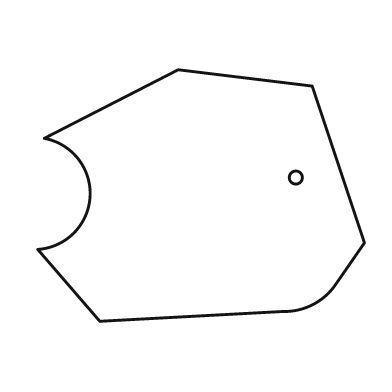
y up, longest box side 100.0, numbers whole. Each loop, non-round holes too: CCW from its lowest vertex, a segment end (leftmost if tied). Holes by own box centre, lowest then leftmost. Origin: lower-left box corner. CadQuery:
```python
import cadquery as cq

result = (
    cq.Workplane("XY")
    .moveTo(19.0, 0.0)
    .lineTo(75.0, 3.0)
    .threePointArc((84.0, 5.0), (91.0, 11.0))
    .lineTo(100.0, 24.0)
    .lineTo(84.0, 72.0)
    .lineTo(43.0, 77.0)
    .lineTo(2.0, 56.0)
    .threePointArc((16.0, 38.0), (0.0, 22.0))
    .close()
    .moveTo(79.0, 44.0)
    .circle(2.0)
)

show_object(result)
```